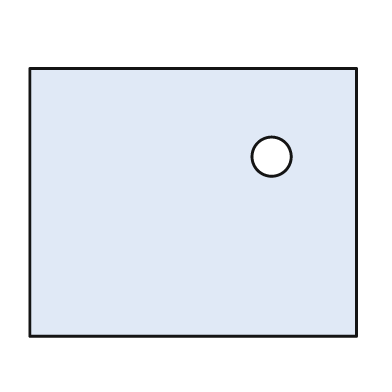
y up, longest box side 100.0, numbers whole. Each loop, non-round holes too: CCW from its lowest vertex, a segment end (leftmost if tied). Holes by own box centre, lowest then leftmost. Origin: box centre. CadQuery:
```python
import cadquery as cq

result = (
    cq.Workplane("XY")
    .moveTo(-50.0, -41.0)
    .lineTo(50.0, -41.0)
    .lineTo(50.0, 41.0)
    .lineTo(-50.0, 41.0)
    .close()
    .moveTo(24.0, 14.0)
    .circle(6.0)
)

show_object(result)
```